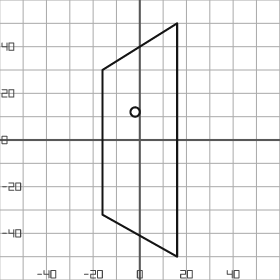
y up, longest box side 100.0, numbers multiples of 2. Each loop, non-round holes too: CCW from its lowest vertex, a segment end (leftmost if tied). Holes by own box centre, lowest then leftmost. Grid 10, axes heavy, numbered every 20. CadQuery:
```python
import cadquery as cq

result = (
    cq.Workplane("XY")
    .moveTo(16.0, -50.0)
    .lineTo(16.0, 50.0)
    .lineTo(-16.0, 30.0)
    .lineTo(-16.0, -32.0)
    .close()
    .moveTo(-2.0, 12.0)
    .circle(2.0)
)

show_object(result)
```